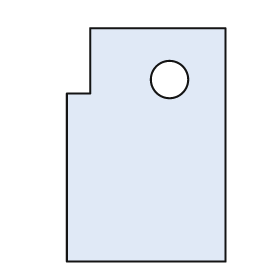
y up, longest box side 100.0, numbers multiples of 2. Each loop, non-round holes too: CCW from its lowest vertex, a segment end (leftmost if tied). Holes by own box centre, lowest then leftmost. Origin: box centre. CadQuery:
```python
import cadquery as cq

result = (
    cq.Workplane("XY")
    .moveTo(-34.0, -50.0)
    .lineTo(34.0, -50.0)
    .lineTo(34.0, 50.0)
    .lineTo(-24.0, 50.0)
    .lineTo(-24.0, 22.0)
    .lineTo(-34.0, 22.0)
    .close()
    .moveTo(10.0, 28.0)
    .circle(8.0)
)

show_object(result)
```